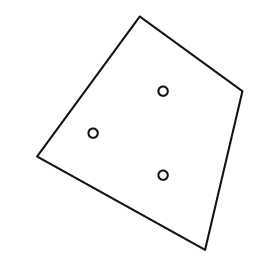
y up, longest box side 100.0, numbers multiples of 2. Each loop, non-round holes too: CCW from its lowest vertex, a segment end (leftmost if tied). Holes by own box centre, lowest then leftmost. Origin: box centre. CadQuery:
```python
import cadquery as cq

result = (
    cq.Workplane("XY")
    .moveTo(28.0, -50.0)
    .lineTo(44.0, 18.0)
    .lineTo(0.0, 50.0)
    .lineTo(-44.0, -10.0)
    .close()
    .moveTo(10.0, -18.0)
    .circle(2.0)
    .moveTo(-20.0, 0.0)
    .circle(2.0)
    .moveTo(10.0, 18.0)
    .circle(2.0)
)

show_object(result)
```